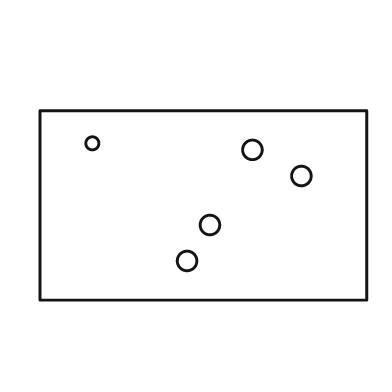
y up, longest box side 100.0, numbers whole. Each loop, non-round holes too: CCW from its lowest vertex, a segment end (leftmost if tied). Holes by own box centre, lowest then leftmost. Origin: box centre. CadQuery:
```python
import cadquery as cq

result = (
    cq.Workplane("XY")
    .moveTo(-50.0, -29.0)
    .lineTo(50.0, -29.0)
    .lineTo(50.0, 29.0)
    .lineTo(-50.0, 29.0)
    .close()
    .moveTo(-5.0, -17.0)
    .circle(3.0)
    .moveTo(2.0, -6.0)
    .circle(3.0)
    .moveTo(30.0, 9.0)
    .circle(3.0)
    .moveTo(15.0, 17.0)
    .circle(3.0)
    .moveTo(-34.0, 19.0)
    .circle(2.0)
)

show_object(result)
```